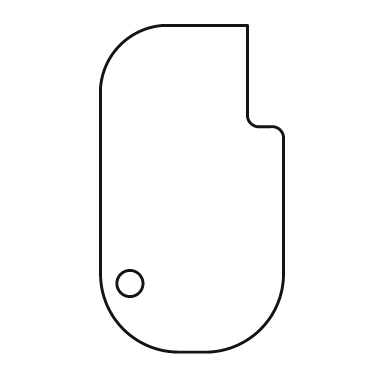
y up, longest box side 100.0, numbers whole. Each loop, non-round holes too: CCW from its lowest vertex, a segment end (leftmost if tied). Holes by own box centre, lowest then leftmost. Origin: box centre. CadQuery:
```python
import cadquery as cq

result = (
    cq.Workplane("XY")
    .moveTo(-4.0, -50.0)
    .lineTo(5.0, -50.0)
    .threePointArc((21.0, -43.0), (28.0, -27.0))
    .lineTo(28.0, 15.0)
    .threePointArc((27.0, 18.0), (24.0, 19.0))
    .lineTo(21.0, 19.0)
    .threePointArc((18.0, 20.0), (17.0, 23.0))
    .lineTo(17.0, 50.0)
    .lineTo(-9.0, 50.0)
    .threePointArc((-22.0, 44.0), (-28.0, 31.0))
    .lineTo(-28.0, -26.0)
    .threePointArc((-21.0, -43.0), (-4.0, -50.0))
    .close()
    .moveTo(-19.0, -29.0)
    .circle(4.0)
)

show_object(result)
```